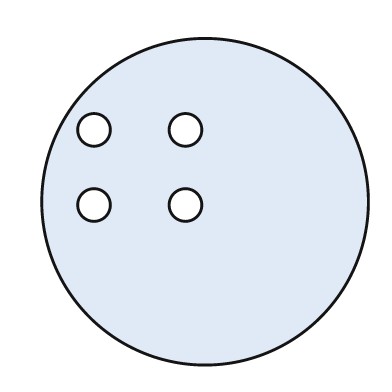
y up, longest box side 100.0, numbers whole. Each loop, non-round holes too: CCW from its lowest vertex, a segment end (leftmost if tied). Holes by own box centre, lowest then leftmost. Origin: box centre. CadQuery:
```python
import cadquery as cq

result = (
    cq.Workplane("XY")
    .moveTo(0.0, 0.0)
    .circle(50.0)
    .moveTo(-34.0, -1.0)
    .circle(5.0)
    .moveTo(-6.0, -1.0)
    .circle(5.0)
    .moveTo(-34.0, 22.0)
    .circle(5.0)
    .moveTo(-6.0, 22.0)
    .circle(5.0)
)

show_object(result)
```